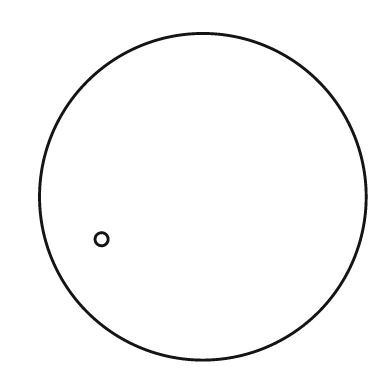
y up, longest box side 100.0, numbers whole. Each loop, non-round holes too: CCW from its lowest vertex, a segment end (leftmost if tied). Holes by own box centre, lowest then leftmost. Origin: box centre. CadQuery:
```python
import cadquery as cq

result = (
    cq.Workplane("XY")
    .moveTo(0.0, 0.0)
    .circle(50.0)
    .moveTo(-31.0, -13.0)
    .circle(2.0)
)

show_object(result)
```